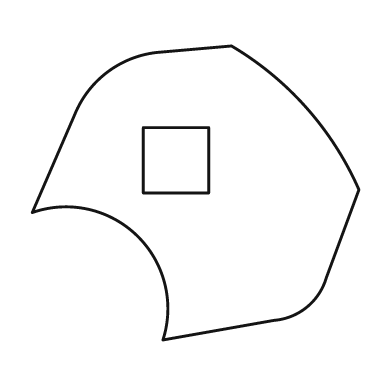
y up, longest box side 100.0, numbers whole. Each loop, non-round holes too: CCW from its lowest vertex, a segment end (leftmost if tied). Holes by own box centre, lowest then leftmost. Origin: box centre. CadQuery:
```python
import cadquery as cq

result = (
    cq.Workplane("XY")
    .moveTo(-10.0, -45.0)
    .lineTo(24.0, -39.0)
    .threePointArc((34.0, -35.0), (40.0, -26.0))
    .lineTo(50.0, 1.0)
    .threePointArc((34.0, 26.0), (11.0, 45.0))
    .lineTo(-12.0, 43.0)
    .threePointArc((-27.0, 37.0), (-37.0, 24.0))
    .lineTo(-50.0, -6.0)
    .threePointArc((-18.0, -13.0), (-10.0, -45.0))
    .close()
    .moveTo(-16.0, 0.0)
    .lineTo(4.0, 0.0)
    .lineTo(4.0, 20.0)
    .lineTo(-16.0, 20.0)
    .close()
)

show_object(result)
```